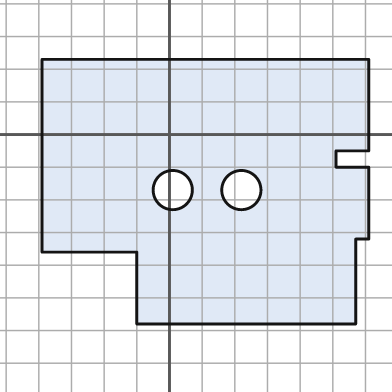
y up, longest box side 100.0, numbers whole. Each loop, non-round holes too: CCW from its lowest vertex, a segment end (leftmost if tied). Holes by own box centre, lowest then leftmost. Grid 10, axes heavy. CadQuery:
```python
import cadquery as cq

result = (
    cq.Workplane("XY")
    .moveTo(-10.0, -58.0)
    .lineTo(57.0, -58.0)
    .lineTo(57.0, -32.0)
    .lineTo(61.0, -32.0)
    .lineTo(61.0, -10.0)
    .lineTo(51.0, -10.0)
    .lineTo(51.0, -5.0)
    .lineTo(61.0, -5.0)
    .lineTo(61.0, 23.0)
    .lineTo(-39.0, 23.0)
    .lineTo(-39.0, -36.0)
    .lineTo(-10.0, -36.0)
    .close()
    .moveTo(1.0, -17.0)
    .circle(6.0)
    .moveTo(22.0, -17.0)
    .circle(6.0)
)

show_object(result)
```